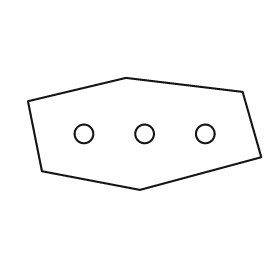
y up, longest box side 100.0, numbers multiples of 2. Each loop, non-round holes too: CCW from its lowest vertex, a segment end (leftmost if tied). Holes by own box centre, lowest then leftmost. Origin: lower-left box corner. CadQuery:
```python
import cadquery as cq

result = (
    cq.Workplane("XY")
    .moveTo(48.0, 0.0)
    .lineTo(100.0, 14.0)
    .lineTo(92.0, 42.0)
    .lineTo(42.0, 48.0)
    .lineTo(0.0, 38.0)
    .lineTo(6.0, 8.0)
    .close()
    .moveTo(24.0, 24.0)
    .circle(4.0)
    .moveTo(50.0, 24.0)
    .circle(4.0)
    .moveTo(76.0, 24.0)
    .circle(4.0)
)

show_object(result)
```